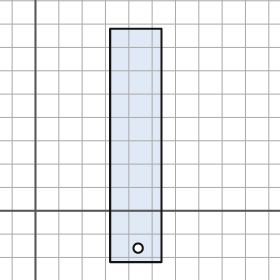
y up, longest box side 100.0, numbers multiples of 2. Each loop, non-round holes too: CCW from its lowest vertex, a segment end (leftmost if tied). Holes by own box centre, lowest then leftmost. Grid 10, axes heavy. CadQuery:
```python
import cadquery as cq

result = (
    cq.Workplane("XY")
    .moveTo(32.0, -22.0)
    .lineTo(54.0, -22.0)
    .lineTo(54.0, 78.0)
    .lineTo(32.0, 78.0)
    .close()
    .moveTo(44.0, -16.0)
    .circle(2.0)
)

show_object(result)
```